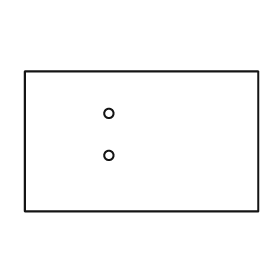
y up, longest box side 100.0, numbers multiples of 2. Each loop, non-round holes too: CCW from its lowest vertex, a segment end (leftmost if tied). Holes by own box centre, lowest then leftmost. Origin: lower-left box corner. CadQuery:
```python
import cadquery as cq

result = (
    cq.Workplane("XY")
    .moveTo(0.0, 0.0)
    .lineTo(100.0, 0.0)
    .lineTo(100.0, 60.0)
    .lineTo(0.0, 60.0)
    .close()
    .moveTo(36.0, 24.0)
    .circle(2.0)
    .moveTo(36.0, 42.0)
    .circle(2.0)
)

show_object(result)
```